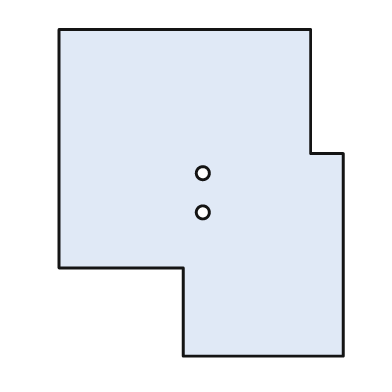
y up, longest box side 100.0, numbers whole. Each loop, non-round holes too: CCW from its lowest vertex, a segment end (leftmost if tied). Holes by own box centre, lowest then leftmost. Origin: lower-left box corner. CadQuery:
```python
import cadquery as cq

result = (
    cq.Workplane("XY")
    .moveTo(38.0, 0.0)
    .lineTo(87.0, 0.0)
    .lineTo(87.0, 62.0)
    .lineTo(77.0, 62.0)
    .lineTo(77.0, 100.0)
    .lineTo(0.0, 100.0)
    .lineTo(0.0, 27.0)
    .lineTo(38.0, 27.0)
    .close()
    .moveTo(44.0, 44.0)
    .circle(2.0)
    .moveTo(44.0, 56.0)
    .circle(2.0)
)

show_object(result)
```